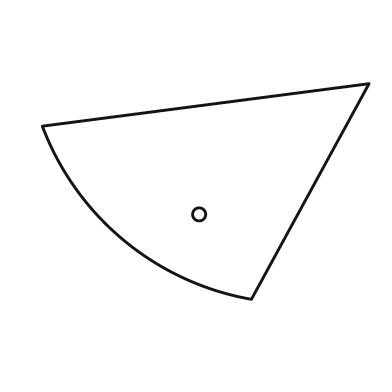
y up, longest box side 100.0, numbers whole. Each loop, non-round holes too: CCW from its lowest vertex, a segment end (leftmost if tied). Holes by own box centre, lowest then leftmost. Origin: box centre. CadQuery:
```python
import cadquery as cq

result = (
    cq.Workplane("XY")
    .moveTo(14.0, -33.0)
    .lineTo(50.0, 33.0)
    .lineTo(-50.0, 20.0)
    .threePointArc((-25.0, -15.0), (14.0, -33.0))
    .close()
    .moveTo(-2.0, -7.0)
    .circle(2.0)
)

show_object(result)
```